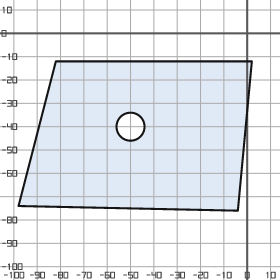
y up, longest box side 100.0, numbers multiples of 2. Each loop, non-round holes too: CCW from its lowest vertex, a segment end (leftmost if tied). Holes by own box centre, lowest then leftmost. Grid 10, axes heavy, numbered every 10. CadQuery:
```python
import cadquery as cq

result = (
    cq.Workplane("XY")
    .moveTo(-4.0, -76.0)
    .lineTo(2.0, -12.0)
    .lineTo(-82.0, -12.0)
    .lineTo(-98.0, -74.0)
    .close()
    .moveTo(-50.0, -40.0)
    .circle(6.0)
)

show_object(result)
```